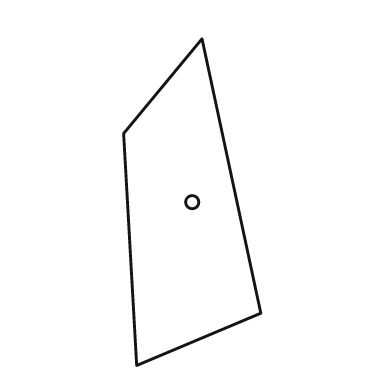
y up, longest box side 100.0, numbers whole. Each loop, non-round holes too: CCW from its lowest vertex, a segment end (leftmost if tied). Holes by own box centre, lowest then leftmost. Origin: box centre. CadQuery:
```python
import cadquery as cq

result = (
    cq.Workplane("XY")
    .moveTo(-17.0, -50.0)
    .lineTo(21.0, -34.0)
    .lineTo(3.0, 50.0)
    .lineTo(-21.0, 21.0)
    .close()
    .moveTo(0.0, 0.0)
    .circle(2.0)
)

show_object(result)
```